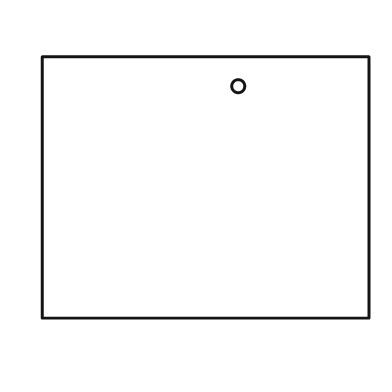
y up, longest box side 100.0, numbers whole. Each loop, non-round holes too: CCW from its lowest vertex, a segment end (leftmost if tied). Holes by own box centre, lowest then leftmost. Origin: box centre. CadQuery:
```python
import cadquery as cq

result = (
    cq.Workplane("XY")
    .moveTo(-50.0, -40.0)
    .lineTo(50.0, -40.0)
    .lineTo(50.0, 40.0)
    .lineTo(-50.0, 40.0)
    .close()
    .moveTo(10.0, 31.0)
    .circle(2.0)
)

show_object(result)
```